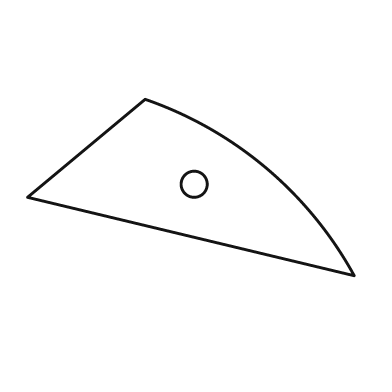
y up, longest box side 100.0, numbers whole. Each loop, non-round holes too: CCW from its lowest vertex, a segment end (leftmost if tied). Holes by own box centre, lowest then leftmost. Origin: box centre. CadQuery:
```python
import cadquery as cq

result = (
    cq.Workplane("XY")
    .moveTo(50.0, -27.0)
    .threePointArc((23.0, 6.0), (-14.0, 27.0))
    .lineTo(-50.0, -3.0)
    .close()
    .moveTo(1.0, 1.0)
    .circle(4.0)
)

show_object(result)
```